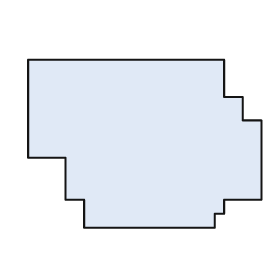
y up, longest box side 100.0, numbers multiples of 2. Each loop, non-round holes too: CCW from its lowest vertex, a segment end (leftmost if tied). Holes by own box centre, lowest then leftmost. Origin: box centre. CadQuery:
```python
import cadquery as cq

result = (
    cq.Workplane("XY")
    .moveTo(-26.0, -36.0)
    .lineTo(30.0, -36.0)
    .lineTo(30.0, -30.0)
    .lineTo(34.0, -30.0)
    .lineTo(34.0, -24.0)
    .lineTo(50.0, -24.0)
    .lineTo(50.0, 10.0)
    .lineTo(42.0, 10.0)
    .lineTo(42.0, 20.0)
    .lineTo(34.0, 20.0)
    .lineTo(34.0, 36.0)
    .lineTo(-50.0, 36.0)
    .lineTo(-50.0, -6.0)
    .lineTo(-34.0, -6.0)
    .lineTo(-34.0, -24.0)
    .lineTo(-26.0, -24.0)
    .close()
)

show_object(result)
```